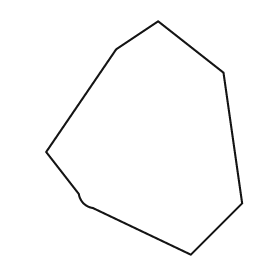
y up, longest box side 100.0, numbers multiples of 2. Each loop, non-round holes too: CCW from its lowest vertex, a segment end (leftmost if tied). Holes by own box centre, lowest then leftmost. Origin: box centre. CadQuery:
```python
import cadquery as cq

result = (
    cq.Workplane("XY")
    .moveTo(20.0, -50.0)
    .lineTo(42.0, -28.0)
    .lineTo(34.0, 28.0)
    .lineTo(6.0, 50.0)
    .lineTo(-12.0, 38.0)
    .lineTo(-42.0, -6.0)
    .lineTo(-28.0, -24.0)
    .threePointArc((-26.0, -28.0), (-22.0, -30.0))
    .close()
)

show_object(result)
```